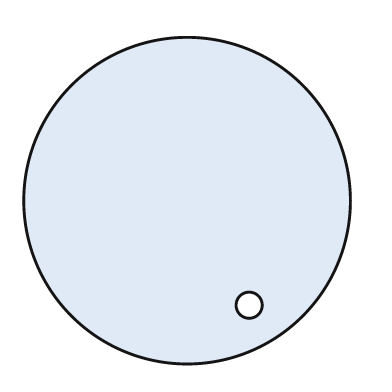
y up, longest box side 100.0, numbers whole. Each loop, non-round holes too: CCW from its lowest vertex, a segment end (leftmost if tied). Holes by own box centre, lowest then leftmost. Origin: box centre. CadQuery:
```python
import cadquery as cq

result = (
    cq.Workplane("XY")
    .moveTo(0.0, 0.0)
    .circle(50.0)
    .moveTo(19.0, -32.0)
    .circle(4.0)
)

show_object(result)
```